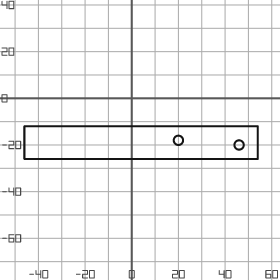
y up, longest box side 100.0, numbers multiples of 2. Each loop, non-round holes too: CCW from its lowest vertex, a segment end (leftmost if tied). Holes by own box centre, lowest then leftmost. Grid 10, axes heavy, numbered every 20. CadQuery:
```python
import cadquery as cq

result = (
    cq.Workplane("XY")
    .moveTo(-46.0, -26.0)
    .lineTo(54.0, -26.0)
    .lineTo(54.0, -12.0)
    .lineTo(-46.0, -12.0)
    .close()
    .moveTo(46.0, -20.0)
    .circle(2.0)
    .moveTo(20.0, -18.0)
    .circle(2.0)
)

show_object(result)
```